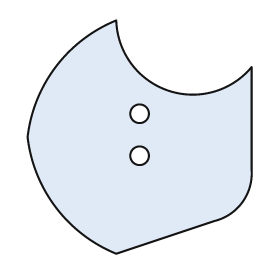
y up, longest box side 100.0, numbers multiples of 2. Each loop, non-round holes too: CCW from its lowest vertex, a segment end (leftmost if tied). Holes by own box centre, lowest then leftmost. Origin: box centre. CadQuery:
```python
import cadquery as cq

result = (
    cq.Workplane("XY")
    .moveTo(-10.0, -50.0)
    .lineTo(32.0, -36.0)
    .threePointArc((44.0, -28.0), (48.0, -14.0))
    .lineTo(48.0, 30.0)
    .threePointArc((12.0, 20.0), (-10.0, 50.0))
    .threePointArc((-36.0, 30.0), (-48.0, 0.0))
    .threePointArc((-36.0, -30.0), (-10.0, -50.0))
    .close()
    .moveTo(0.0, -8.0)
    .circle(4.0)
    .moveTo(0.0, 10.0)
    .circle(4.0)
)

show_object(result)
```